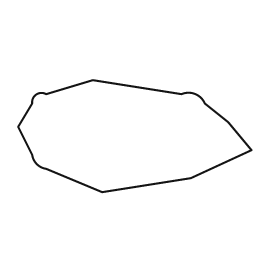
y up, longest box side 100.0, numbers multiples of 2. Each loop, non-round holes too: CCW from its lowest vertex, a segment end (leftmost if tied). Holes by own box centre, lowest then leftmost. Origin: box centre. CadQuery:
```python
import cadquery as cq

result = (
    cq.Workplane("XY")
    .moveTo(-14.0, -24.0)
    .lineTo(24.0, -18.0)
    .lineTo(50.0, -6.0)
    .lineTo(40.0, 6.0)
    .lineTo(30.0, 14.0)
    .threePointArc((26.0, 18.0), (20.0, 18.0))
    .lineTo(-18.0, 24.0)
    .lineTo(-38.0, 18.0)
    .threePointArc((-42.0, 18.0), (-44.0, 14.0))
    .lineTo(-50.0, 4.0)
    .lineTo(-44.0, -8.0)
    .threePointArc((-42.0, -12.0), (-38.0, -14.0))
    .close()
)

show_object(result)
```